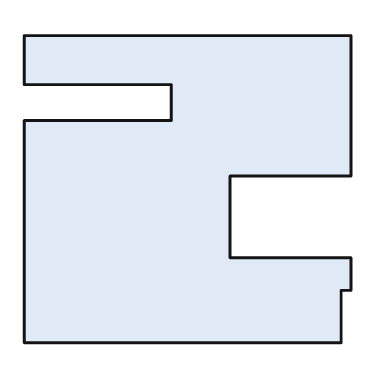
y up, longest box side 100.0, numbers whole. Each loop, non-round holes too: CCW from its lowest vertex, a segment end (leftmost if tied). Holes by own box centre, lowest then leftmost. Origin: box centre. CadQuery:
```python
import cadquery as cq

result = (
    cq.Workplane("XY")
    .moveTo(-50.0, -47.0)
    .lineTo(47.0, -47.0)
    .lineTo(47.0, -31.0)
    .lineTo(50.0, -31.0)
    .lineTo(50.0, -21.0)
    .lineTo(13.0, -21.0)
    .lineTo(13.0, 4.0)
    .lineTo(50.0, 4.0)
    .lineTo(50.0, 47.0)
    .lineTo(-50.0, 47.0)
    .lineTo(-50.0, 32.0)
    .lineTo(-5.0, 32.0)
    .lineTo(-5.0, 21.0)
    .lineTo(-50.0, 21.0)
    .close()
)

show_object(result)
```